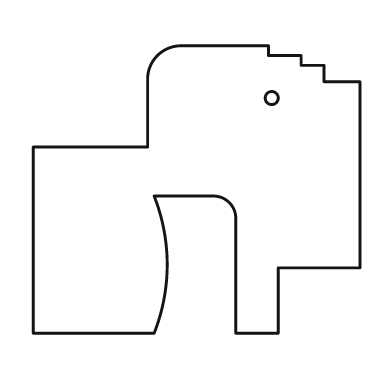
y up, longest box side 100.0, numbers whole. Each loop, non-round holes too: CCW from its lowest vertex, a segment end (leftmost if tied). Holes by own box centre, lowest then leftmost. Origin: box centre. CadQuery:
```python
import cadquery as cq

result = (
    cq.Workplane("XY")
    .moveTo(-50.0, -44.0)
    .lineTo(-13.0, -44.0)
    .threePointArc((-9.0, -23.0), (-13.0, -2.0))
    .lineTo(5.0, -2.0)
    .threePointArc((10.0, -4.0), (12.0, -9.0))
    .lineTo(12.0, -44.0)
    .lineTo(25.0, -44.0)
    .lineTo(25.0, -24.0)
    .lineTo(50.0, -24.0)
    .lineTo(50.0, 33.0)
    .lineTo(39.0, 33.0)
    .lineTo(39.0, 38.0)
    .lineTo(32.0, 38.0)
    .lineTo(32.0, 41.0)
    .lineTo(22.0, 41.0)
    .lineTo(22.0, 44.0)
    .lineTo(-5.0, 44.0)
    .threePointArc((-12.0, 41.0), (-15.0, 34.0))
    .lineTo(-15.0, 13.0)
    .lineTo(-50.0, 13.0)
    .close()
    .moveTo(23.0, 28.0)
    .circle(2.0)
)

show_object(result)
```